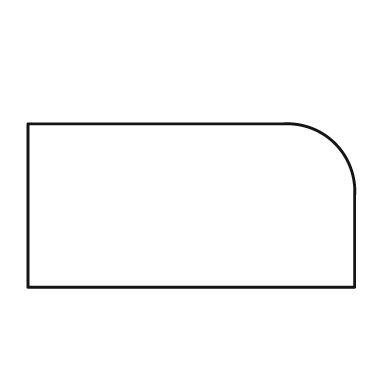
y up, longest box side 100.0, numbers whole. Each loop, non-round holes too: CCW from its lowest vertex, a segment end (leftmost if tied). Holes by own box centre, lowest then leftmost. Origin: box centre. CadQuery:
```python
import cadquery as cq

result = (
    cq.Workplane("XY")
    .moveTo(-50.0, -25.0)
    .lineTo(50.0, -25.0)
    .lineTo(50.0, 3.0)
    .threePointArc((44.0, 19.0), (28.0, 25.0))
    .lineTo(-50.0, 25.0)
    .close()
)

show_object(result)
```